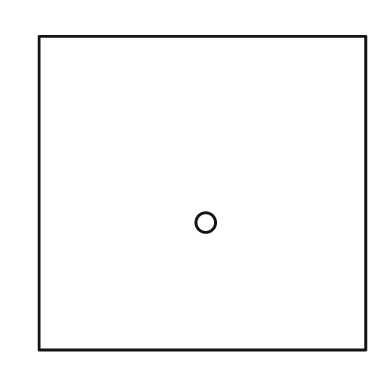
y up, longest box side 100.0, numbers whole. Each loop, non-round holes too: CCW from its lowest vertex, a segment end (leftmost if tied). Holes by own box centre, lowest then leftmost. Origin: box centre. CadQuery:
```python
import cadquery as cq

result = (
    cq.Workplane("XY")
    .moveTo(-50.0, -48.0)
    .lineTo(50.0, -48.0)
    .lineTo(50.0, 48.0)
    .lineTo(-50.0, 48.0)
    .close()
    .moveTo(1.0, -9.0)
    .circle(3.0)
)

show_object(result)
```